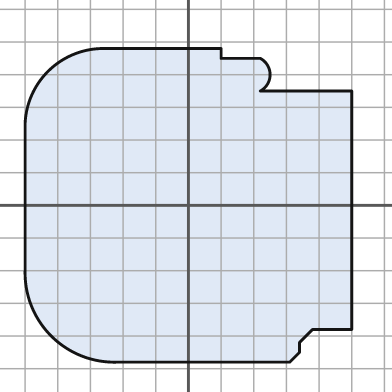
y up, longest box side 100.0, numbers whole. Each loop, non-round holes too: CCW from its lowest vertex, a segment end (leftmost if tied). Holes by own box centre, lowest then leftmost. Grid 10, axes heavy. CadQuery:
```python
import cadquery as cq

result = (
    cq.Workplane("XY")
    .moveTo(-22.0, -48.0)
    .lineTo(31.0, -48.0)
    .lineTo(34.0, -45.0)
    .lineTo(34.0, -42.0)
    .lineTo(38.0, -38.0)
    .lineTo(50.0, -38.0)
    .lineTo(50.0, 35.0)
    .lineTo(22.0, 35.0)
    .threePointArc((25.0, 40.0), (22.0, 45.0))
    .lineTo(10.0, 45.0)
    .lineTo(10.0, 48.0)
    .lineTo(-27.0, 48.0)
    .threePointArc((-43.0, 41.0), (-50.0, 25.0))
    .lineTo(-50.0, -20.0)
    .threePointArc((-42.0, -40.0), (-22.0, -48.0))
    .close()
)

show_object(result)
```